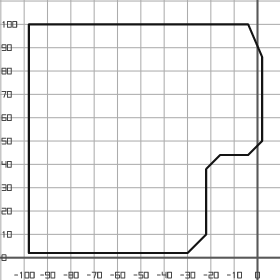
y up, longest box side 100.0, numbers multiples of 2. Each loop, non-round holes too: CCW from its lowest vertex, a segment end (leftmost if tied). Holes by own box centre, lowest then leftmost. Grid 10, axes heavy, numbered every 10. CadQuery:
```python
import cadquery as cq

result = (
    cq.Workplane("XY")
    .moveTo(-98.0, 2.0)
    .lineTo(-30.0, 2.0)
    .lineTo(-22.0, 10.0)
    .lineTo(-22.0, 38.0)
    .lineTo(-16.0, 44.0)
    .lineTo(-4.0, 44.0)
    .lineTo(2.0, 50.0)
    .lineTo(2.0, 86.0)
    .lineTo(-4.0, 100.0)
    .lineTo(-98.0, 100.0)
    .close()
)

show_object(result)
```